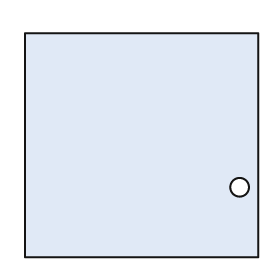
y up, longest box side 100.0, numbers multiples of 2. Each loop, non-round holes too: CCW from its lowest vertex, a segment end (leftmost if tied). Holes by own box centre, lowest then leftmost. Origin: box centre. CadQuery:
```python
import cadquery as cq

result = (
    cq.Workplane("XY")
    .moveTo(-50.0, -48.0)
    .lineTo(50.0, -48.0)
    .lineTo(50.0, 48.0)
    .lineTo(-50.0, 48.0)
    .close()
    .moveTo(42.0, -18.0)
    .circle(4.0)
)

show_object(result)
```